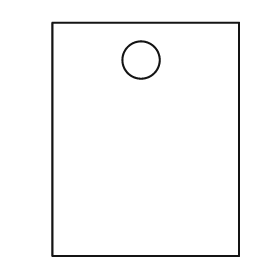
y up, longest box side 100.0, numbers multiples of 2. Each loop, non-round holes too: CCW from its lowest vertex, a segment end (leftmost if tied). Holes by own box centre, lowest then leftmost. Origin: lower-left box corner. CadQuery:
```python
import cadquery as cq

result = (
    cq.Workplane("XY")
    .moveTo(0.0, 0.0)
    .lineTo(80.0, 0.0)
    .lineTo(80.0, 100.0)
    .lineTo(0.0, 100.0)
    .close()
    .moveTo(38.0, 84.0)
    .circle(8.0)
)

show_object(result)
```